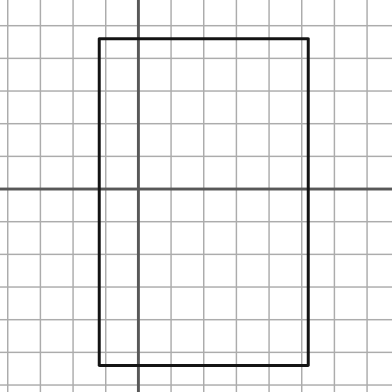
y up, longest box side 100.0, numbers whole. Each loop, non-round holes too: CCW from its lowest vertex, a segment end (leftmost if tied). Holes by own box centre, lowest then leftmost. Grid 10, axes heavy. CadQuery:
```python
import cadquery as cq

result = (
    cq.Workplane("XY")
    .moveTo(-12.0, -54.0)
    .lineTo(52.0, -54.0)
    .lineTo(52.0, 46.0)
    .lineTo(-12.0, 46.0)
    .close()
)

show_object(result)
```